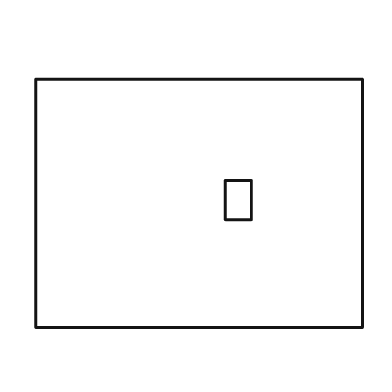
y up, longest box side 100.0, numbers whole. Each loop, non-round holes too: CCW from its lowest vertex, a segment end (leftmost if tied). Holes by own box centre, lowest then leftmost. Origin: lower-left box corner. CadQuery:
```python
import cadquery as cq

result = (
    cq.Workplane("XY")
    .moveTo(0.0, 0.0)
    .lineTo(100.0, 0.0)
    .lineTo(100.0, 76.0)
    .lineTo(0.0, 76.0)
    .close()
    .moveTo(58.0, 33.0)
    .lineTo(66.0, 33.0)
    .lineTo(66.0, 45.0)
    .lineTo(58.0, 45.0)
    .close()
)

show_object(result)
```